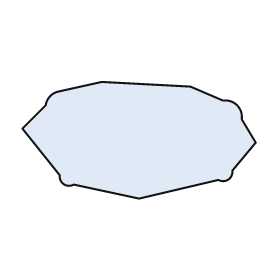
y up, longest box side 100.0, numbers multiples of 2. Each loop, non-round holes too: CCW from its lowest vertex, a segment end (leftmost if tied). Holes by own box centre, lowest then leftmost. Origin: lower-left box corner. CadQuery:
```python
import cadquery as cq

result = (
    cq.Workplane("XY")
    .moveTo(50.0, 0.0)
    .lineTo(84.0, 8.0)
    .threePointArc((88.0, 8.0), (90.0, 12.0))
    .lineTo(100.0, 24.0)
    .lineTo(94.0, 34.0)
    .threePointArc((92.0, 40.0), (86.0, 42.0))
    .lineTo(72.0, 48.0)
    .lineTo(34.0, 50.0)
    .lineTo(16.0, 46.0)
    .threePointArc((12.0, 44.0), (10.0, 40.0))
    .lineTo(0.0, 30.0)
    .lineTo(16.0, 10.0)
    .threePointArc((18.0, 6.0), (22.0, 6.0))
    .close()
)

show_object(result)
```